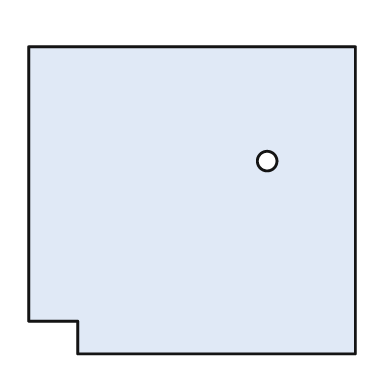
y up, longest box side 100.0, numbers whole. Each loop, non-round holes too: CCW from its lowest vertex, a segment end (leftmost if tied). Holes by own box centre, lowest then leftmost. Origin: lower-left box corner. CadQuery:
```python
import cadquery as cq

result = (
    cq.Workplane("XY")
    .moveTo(15.0, 0.0)
    .lineTo(100.0, 0.0)
    .lineTo(100.0, 94.0)
    .lineTo(0.0, 94.0)
    .lineTo(0.0, 10.0)
    .lineTo(15.0, 10.0)
    .close()
    .moveTo(73.0, 59.0)
    .circle(3.0)
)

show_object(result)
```